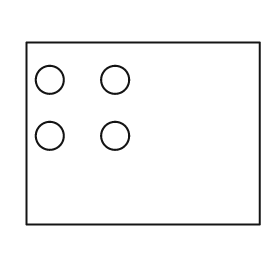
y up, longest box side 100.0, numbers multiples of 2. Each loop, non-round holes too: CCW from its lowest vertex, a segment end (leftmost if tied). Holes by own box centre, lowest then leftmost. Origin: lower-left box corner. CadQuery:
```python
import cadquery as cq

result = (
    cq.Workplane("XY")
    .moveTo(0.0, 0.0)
    .lineTo(100.0, 0.0)
    .lineTo(100.0, 78.0)
    .lineTo(0.0, 78.0)
    .close()
    .moveTo(10.0, 38.0)
    .circle(6.0)
    .moveTo(38.0, 38.0)
    .circle(6.0)
    .moveTo(10.0, 62.0)
    .circle(6.0)
    .moveTo(38.0, 62.0)
    .circle(6.0)
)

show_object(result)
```